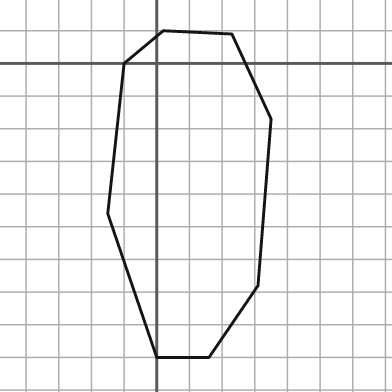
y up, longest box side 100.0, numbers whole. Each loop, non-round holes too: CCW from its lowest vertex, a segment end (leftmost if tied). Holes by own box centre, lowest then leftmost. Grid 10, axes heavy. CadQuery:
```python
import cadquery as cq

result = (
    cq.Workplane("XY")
    .moveTo(0.0, -90.0)
    .lineTo(16.0, -90.0)
    .lineTo(31.0, -68.0)
    .lineTo(35.0, -17.0)
    .lineTo(23.0, 9.0)
    .lineTo(2.0, 10.0)
    .lineTo(-10.0, 0.0)
    .lineTo(-15.0, -46.0)
    .close()
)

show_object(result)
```